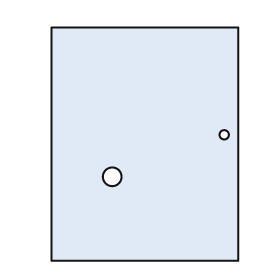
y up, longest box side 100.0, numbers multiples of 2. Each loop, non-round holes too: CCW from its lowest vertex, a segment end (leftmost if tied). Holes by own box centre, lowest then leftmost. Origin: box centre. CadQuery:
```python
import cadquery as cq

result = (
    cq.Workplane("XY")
    .moveTo(-40.0, -50.0)
    .lineTo(40.0, -50.0)
    .lineTo(40.0, 50.0)
    .lineTo(-40.0, 50.0)
    .close()
    .moveTo(-14.0, -14.0)
    .circle(4.0)
    .moveTo(34.0, 4.0)
    .circle(2.0)
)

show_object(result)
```